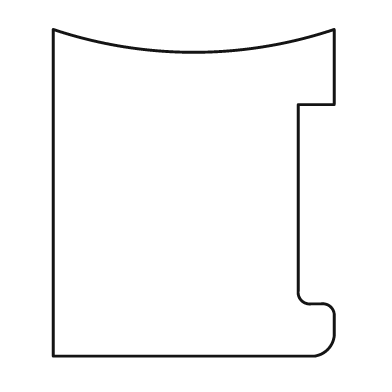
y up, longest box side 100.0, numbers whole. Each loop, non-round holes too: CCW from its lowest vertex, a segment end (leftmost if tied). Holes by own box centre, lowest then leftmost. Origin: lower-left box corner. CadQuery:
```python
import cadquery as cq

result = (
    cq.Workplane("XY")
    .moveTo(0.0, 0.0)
    .lineTo(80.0, 0.0)
    .threePointArc((84.0, 2.0), (86.0, 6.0))
    .lineTo(86.0, 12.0)
    .threePointArc((85.0, 15.0), (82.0, 16.0))
    .lineTo(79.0, 16.0)
    .threePointArc((76.0, 17.0), (75.0, 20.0))
    .lineTo(75.0, 77.0)
    .lineTo(86.0, 77.0)
    .lineTo(86.0, 100.0)
    .threePointArc((43.0, 93.0), (0.0, 100.0))
    .close()
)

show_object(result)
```